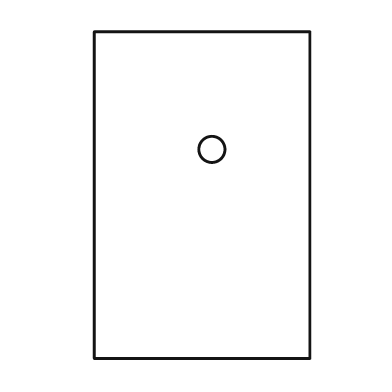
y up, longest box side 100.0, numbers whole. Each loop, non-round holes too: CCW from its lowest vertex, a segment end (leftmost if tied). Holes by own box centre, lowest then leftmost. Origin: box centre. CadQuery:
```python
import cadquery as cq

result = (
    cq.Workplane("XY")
    .moveTo(-33.0, -50.0)
    .lineTo(33.0, -50.0)
    .lineTo(33.0, 50.0)
    .lineTo(-33.0, 50.0)
    .close()
    .moveTo(3.0, 14.0)
    .circle(4.0)
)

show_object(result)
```